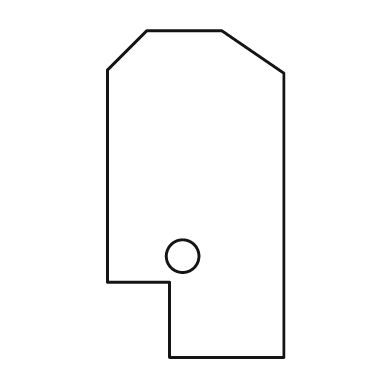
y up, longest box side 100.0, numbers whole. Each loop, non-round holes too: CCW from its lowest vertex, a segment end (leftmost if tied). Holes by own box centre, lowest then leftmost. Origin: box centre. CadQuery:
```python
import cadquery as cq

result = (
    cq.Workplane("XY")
    .moveTo(-8.0, -50.0)
    .lineTo(27.0, -50.0)
    .lineTo(27.0, 37.0)
    .lineTo(8.0, 50.0)
    .lineTo(-15.0, 50.0)
    .lineTo(-27.0, 38.0)
    .lineTo(-27.0, -27.0)
    .lineTo(-8.0, -27.0)
    .close()
    .moveTo(-4.0, -19.0)
    .circle(5.0)
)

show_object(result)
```